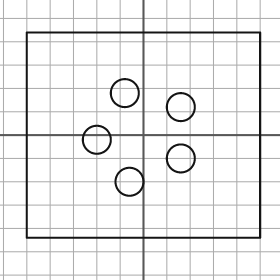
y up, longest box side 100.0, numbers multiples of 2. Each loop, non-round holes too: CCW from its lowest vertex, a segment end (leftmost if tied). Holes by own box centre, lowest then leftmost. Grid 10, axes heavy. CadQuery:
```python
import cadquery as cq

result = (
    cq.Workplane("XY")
    .moveTo(-50.0, -44.0)
    .lineTo(50.0, -44.0)
    .lineTo(50.0, 44.0)
    .lineTo(-50.0, 44.0)
    .close()
    .moveTo(-6.0, -20.0)
    .circle(6.0)
    .moveTo(16.0, -10.0)
    .circle(6.0)
    .moveTo(-20.0, -2.0)
    .circle(6.0)
    .moveTo(16.0, 12.0)
    .circle(6.0)
    .moveTo(-8.0, 18.0)
    .circle(6.0)
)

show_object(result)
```